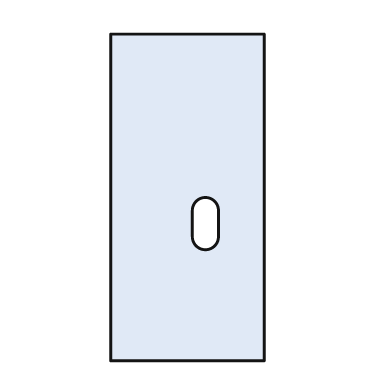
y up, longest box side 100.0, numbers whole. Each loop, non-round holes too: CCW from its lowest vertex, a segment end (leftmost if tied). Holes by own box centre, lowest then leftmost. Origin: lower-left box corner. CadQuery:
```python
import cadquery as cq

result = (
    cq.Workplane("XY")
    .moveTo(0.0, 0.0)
    .lineTo(47.0, 0.0)
    .lineTo(47.0, 100.0)
    .lineTo(0.0, 100.0)
    .close()
    .moveTo(25.0, 38.0)
    .threePointArc((29.0, 34.0), (33.0, 38.0))
    .lineTo(33.0, 46.0)
    .threePointArc((29.0, 50.0), (25.0, 46.0))
    .close()
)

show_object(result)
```